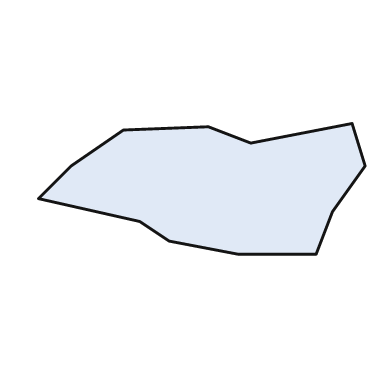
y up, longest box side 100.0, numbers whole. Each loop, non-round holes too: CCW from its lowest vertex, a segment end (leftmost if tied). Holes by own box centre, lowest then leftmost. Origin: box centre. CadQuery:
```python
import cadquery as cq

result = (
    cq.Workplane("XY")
    .moveTo(11.0, -20.0)
    .lineTo(35.0, -20.0)
    .lineTo(40.0, -7.0)
    .lineTo(50.0, 7.0)
    .lineTo(46.0, 20.0)
    .lineTo(15.0, 14.0)
    .lineTo(2.0, 19.0)
    .lineTo(-24.0, 18.0)
    .lineTo(-40.0, 7.0)
    .lineTo(-50.0, -3.0)
    .lineTo(-19.0, -10.0)
    .lineTo(-10.0, -16.0)
    .close()
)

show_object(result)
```